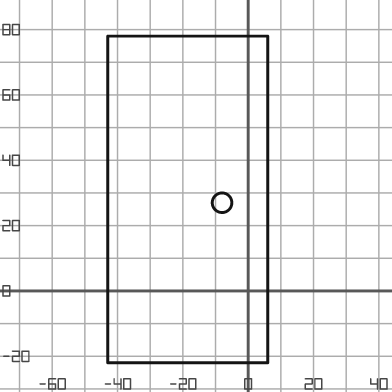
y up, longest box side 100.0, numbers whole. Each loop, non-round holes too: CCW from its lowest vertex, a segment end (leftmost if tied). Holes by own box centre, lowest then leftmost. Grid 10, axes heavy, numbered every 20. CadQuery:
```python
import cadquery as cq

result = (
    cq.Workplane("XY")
    .moveTo(-43.0, -22.0)
    .lineTo(6.0, -22.0)
    .lineTo(6.0, 78.0)
    .lineTo(-43.0, 78.0)
    .close()
    .moveTo(-8.0, 27.0)
    .circle(3.0)
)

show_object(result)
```